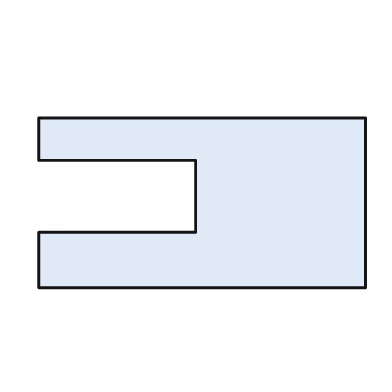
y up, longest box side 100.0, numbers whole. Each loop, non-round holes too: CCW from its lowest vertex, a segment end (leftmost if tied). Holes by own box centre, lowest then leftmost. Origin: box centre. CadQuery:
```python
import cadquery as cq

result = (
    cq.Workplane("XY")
    .moveTo(-50.0, -26.0)
    .lineTo(50.0, -26.0)
    .lineTo(50.0, 26.0)
    .lineTo(-50.0, 26.0)
    .lineTo(-50.0, 13.0)
    .lineTo(-2.0, 13.0)
    .lineTo(-2.0, -9.0)
    .lineTo(-50.0, -9.0)
    .close()
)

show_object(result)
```